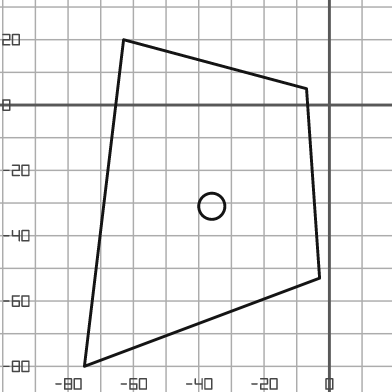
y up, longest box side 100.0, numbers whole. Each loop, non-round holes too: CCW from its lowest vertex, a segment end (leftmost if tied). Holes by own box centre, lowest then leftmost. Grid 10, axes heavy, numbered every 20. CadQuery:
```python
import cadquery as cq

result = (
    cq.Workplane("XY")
    .moveTo(-75.0, -80.0)
    .lineTo(-3.0, -53.0)
    .lineTo(-7.0, 5.0)
    .lineTo(-63.0, 20.0)
    .close()
    .moveTo(-36.0, -31.0)
    .circle(4.0)
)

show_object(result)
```